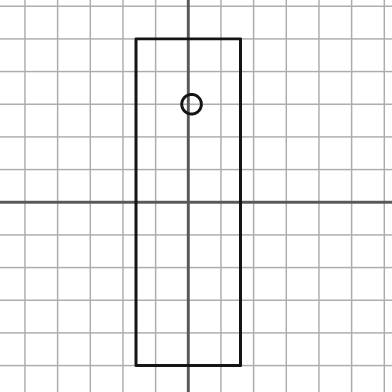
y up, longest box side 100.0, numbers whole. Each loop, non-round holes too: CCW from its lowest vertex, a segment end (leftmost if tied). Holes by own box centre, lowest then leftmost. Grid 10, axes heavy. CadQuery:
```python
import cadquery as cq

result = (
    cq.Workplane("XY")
    .moveTo(-16.0, -50.0)
    .lineTo(16.0, -50.0)
    .lineTo(16.0, 50.0)
    .lineTo(-16.0, 50.0)
    .close()
    .moveTo(1.0, 30.0)
    .circle(3.0)
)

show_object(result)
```